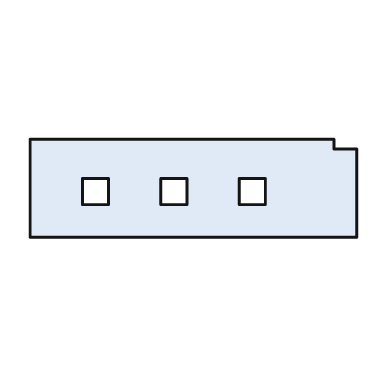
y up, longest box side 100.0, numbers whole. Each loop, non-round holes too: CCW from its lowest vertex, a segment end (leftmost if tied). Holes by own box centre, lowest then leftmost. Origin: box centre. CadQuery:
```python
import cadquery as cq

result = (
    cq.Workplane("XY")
    .moveTo(-50.0, -15.0)
    .lineTo(50.0, -15.0)
    .lineTo(50.0, 12.0)
    .lineTo(43.0, 12.0)
    .lineTo(43.0, 15.0)
    .lineTo(-50.0, 15.0)
    .close()
    .moveTo(-34.0, -5.0)
    .lineTo(-26.0, -5.0)
    .lineTo(-26.0, 3.0)
    .lineTo(-34.0, 3.0)
    .close()
    .moveTo(-10.0, -5.0)
    .lineTo(-2.0, -5.0)
    .lineTo(-2.0, 3.0)
    .lineTo(-10.0, 3.0)
    .close()
    .moveTo(14.0, -5.0)
    .lineTo(22.0, -5.0)
    .lineTo(22.0, 3.0)
    .lineTo(14.0, 3.0)
    .close()
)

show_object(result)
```